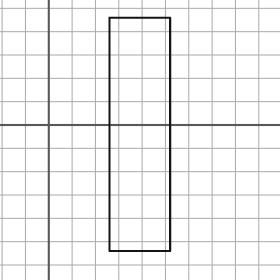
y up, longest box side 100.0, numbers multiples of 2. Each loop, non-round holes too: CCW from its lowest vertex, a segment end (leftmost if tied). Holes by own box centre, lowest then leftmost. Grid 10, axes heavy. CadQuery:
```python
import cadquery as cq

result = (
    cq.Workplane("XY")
    .moveTo(26.0, -54.0)
    .lineTo(52.0, -54.0)
    .lineTo(52.0, 46.0)
    .lineTo(26.0, 46.0)
    .close()
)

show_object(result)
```